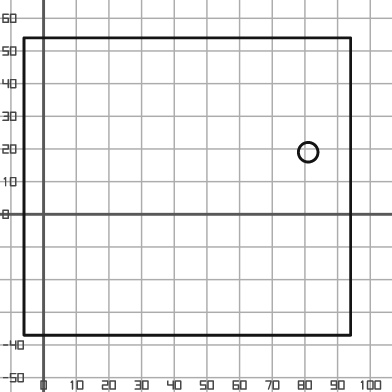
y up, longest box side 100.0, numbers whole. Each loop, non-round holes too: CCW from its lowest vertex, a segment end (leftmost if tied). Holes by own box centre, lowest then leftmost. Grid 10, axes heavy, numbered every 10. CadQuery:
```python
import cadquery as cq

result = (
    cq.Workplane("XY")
    .moveTo(-6.0, -37.0)
    .lineTo(94.0, -37.0)
    .lineTo(94.0, 54.0)
    .lineTo(-6.0, 54.0)
    .close()
    .moveTo(81.0, 19.0)
    .circle(3.0)
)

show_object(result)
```